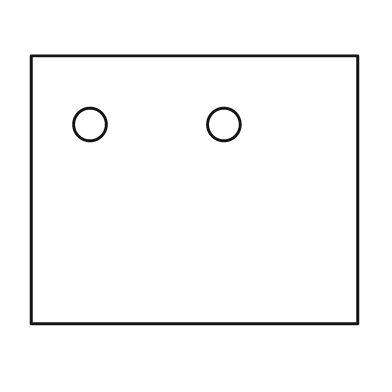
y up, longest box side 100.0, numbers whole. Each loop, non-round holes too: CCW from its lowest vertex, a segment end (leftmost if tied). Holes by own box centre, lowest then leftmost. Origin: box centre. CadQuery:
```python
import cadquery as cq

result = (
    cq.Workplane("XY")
    .moveTo(-50.0, -41.0)
    .lineTo(50.0, -41.0)
    .lineTo(50.0, 41.0)
    .lineTo(-50.0, 41.0)
    .close()
    .moveTo(-32.0, 20.0)
    .circle(5.0)
    .moveTo(9.0, 20.0)
    .circle(5.0)
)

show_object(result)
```